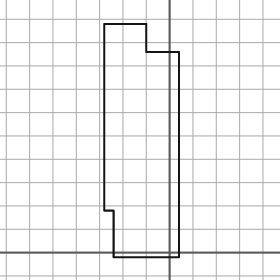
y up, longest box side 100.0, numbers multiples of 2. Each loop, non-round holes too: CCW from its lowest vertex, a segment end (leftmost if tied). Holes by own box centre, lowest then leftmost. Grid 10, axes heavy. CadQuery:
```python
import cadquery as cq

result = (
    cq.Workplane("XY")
    .moveTo(-24.0, -2.0)
    .lineTo(4.0, -2.0)
    .lineTo(4.0, 86.0)
    .lineTo(-10.0, 86.0)
    .lineTo(-10.0, 98.0)
    .lineTo(-28.0, 98.0)
    .lineTo(-28.0, 18.0)
    .lineTo(-24.0, 18.0)
    .close()
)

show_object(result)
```